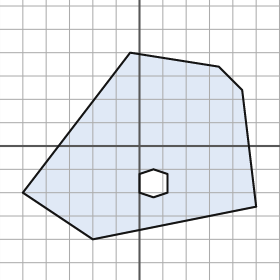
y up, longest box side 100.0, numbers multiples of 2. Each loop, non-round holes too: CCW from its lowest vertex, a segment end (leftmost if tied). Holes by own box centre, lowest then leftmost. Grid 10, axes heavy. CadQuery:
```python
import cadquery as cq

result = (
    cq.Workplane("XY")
    .moveTo(-20.0, -40.0)
    .lineTo(50.0, -26.0)
    .lineTo(44.0, 24.0)
    .lineTo(34.0, 34.0)
    .lineTo(-4.0, 40.0)
    .lineTo(-50.0, -20.0)
    .close()
    .moveTo(6.0, -22.0)
    .lineTo(12.0, -20.0)
    .lineTo(12.0, -12.0)
    .lineTo(6.0, -10.0)
    .lineTo(0.0, -12.0)
    .lineTo(0.0, -20.0)
    .close()
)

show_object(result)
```